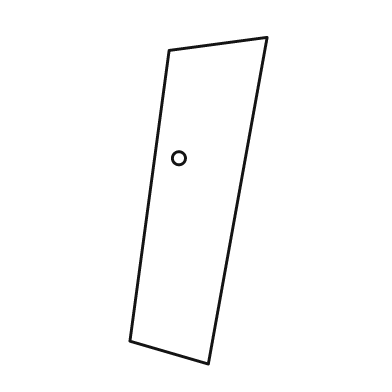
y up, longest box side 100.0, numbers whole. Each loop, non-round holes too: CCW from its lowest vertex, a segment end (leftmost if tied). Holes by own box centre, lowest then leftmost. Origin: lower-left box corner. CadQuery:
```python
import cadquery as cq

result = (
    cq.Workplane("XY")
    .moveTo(24.0, 0.0)
    .lineTo(42.0, 100.0)
    .lineTo(12.0, 96.0)
    .lineTo(0.0, 7.0)
    .close()
    .moveTo(15.0, 63.0)
    .circle(2.0)
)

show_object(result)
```